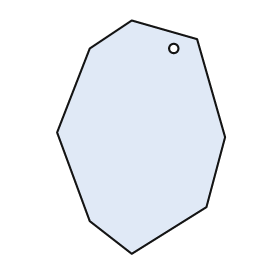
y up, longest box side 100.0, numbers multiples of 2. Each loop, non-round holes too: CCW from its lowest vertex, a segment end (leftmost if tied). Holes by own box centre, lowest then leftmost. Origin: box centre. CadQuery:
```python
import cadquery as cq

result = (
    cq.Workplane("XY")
    .moveTo(-4.0, -50.0)
    .lineTo(28.0, -30.0)
    .lineTo(36.0, 0.0)
    .lineTo(24.0, 42.0)
    .lineTo(-4.0, 50.0)
    .lineTo(-22.0, 38.0)
    .lineTo(-36.0, 2.0)
    .lineTo(-22.0, -36.0)
    .close()
    .moveTo(14.0, 38.0)
    .circle(2.0)
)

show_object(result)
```